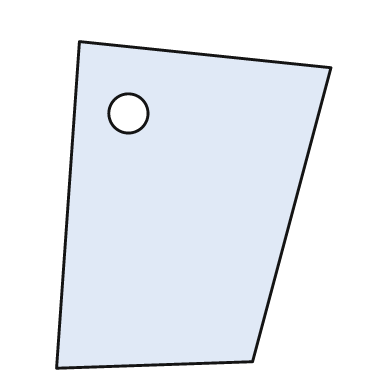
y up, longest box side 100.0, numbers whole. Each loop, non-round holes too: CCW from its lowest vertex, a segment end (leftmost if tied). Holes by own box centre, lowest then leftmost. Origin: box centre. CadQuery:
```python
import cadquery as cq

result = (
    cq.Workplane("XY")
    .moveTo(-42.0, -50.0)
    .lineTo(18.0, -48.0)
    .lineTo(42.0, 42.0)
    .lineTo(-35.0, 50.0)
    .close()
    .moveTo(-20.0, 28.0)
    .circle(6.0)
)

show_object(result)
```